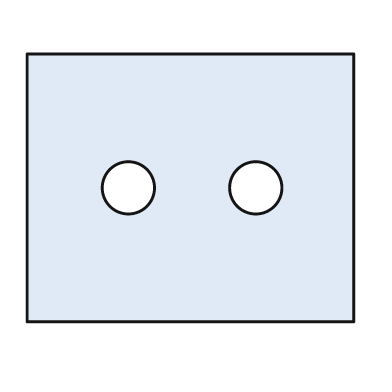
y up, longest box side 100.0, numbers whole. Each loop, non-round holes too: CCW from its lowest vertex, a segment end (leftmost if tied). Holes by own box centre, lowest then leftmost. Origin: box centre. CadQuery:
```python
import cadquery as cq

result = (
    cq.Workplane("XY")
    .moveTo(-50.0, -41.0)
    .lineTo(50.0, -41.0)
    .lineTo(50.0, 41.0)
    .lineTo(-50.0, 41.0)
    .close()
    .moveTo(-19.0, 0.0)
    .circle(8.0)
    .moveTo(20.0, 0.0)
    .circle(8.0)
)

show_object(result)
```